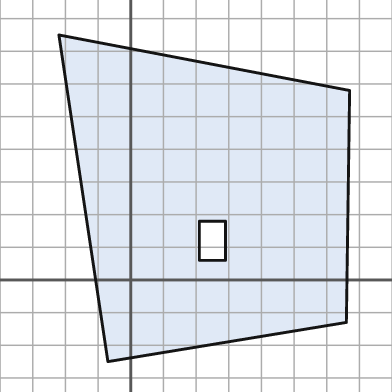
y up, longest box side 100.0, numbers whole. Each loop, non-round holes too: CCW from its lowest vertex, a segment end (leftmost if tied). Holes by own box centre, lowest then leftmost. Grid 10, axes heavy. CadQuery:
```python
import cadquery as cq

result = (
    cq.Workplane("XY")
    .moveTo(-7.0, -25.0)
    .lineTo(66.0, -13.0)
    .lineTo(67.0, 58.0)
    .lineTo(-22.0, 75.0)
    .close()
    .moveTo(21.0, 6.0)
    .lineTo(29.0, 6.0)
    .lineTo(29.0, 18.0)
    .lineTo(21.0, 18.0)
    .close()
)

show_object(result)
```